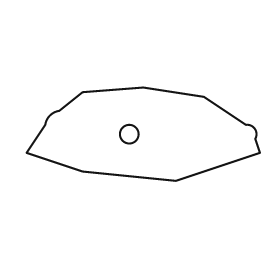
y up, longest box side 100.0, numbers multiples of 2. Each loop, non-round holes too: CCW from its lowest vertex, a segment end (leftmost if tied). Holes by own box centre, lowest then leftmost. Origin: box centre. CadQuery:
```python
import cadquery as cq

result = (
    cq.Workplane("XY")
    .moveTo(14.0, -20.0)
    .lineTo(50.0, -8.0)
    .lineTo(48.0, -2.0)
    .threePointArc((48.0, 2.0), (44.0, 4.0))
    .lineTo(26.0, 16.0)
    .lineTo(0.0, 20.0)
    .lineTo(-26.0, 18.0)
    .lineTo(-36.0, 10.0)
    .threePointArc((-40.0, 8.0), (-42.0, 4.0))
    .lineTo(-50.0, -8.0)
    .lineTo(-26.0, -16.0)
    .close()
    .moveTo(-6.0, 0.0)
    .circle(4.0)
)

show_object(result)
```